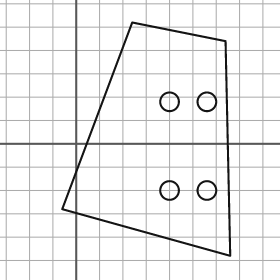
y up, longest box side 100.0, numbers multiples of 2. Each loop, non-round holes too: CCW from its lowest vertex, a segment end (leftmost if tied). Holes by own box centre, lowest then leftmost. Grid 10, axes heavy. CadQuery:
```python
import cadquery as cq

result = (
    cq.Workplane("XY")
    .moveTo(66.0, -48.0)
    .lineTo(64.0, 44.0)
    .lineTo(24.0, 52.0)
    .lineTo(-6.0, -28.0)
    .close()
    .moveTo(40.0, -20.0)
    .circle(4.0)
    .moveTo(56.0, -20.0)
    .circle(4.0)
    .moveTo(40.0, 18.0)
    .circle(4.0)
    .moveTo(56.0, 18.0)
    .circle(4.0)
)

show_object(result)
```